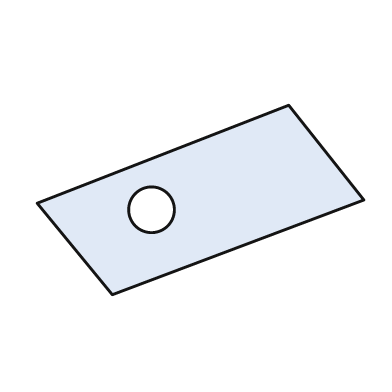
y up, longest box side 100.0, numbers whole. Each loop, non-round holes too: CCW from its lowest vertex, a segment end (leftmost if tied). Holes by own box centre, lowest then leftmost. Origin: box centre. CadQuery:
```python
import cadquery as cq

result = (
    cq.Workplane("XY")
    .moveTo(-27.0, -29.0)
    .lineTo(50.0, 0.0)
    .lineTo(27.0, 29.0)
    .lineTo(-50.0, -1.0)
    .close()
    .moveTo(-15.0, -3.0)
    .circle(7.0)
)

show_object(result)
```